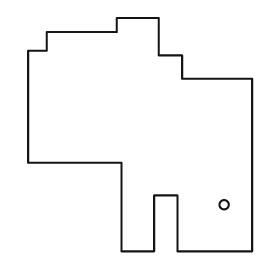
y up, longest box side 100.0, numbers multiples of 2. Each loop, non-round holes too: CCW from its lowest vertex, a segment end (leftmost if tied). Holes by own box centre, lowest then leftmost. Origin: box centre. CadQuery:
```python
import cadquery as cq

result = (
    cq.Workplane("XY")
    .moveTo(-8.0, -50.0)
    .lineTo(6.0, -50.0)
    .lineTo(6.0, -26.0)
    .lineTo(16.0, -26.0)
    .lineTo(16.0, -50.0)
    .lineTo(48.0, -50.0)
    .lineTo(48.0, 24.0)
    .lineTo(18.0, 24.0)
    .lineTo(18.0, 34.0)
    .lineTo(8.0, 34.0)
    .lineTo(8.0, 50.0)
    .lineTo(-10.0, 50.0)
    .lineTo(-10.0, 44.0)
    .lineTo(-40.0, 44.0)
    .lineTo(-40.0, 36.0)
    .lineTo(-48.0, 36.0)
    .lineTo(-48.0, -12.0)
    .lineTo(-8.0, -12.0)
    .close()
    .moveTo(36.0, -30.0)
    .circle(2.0)
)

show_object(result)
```